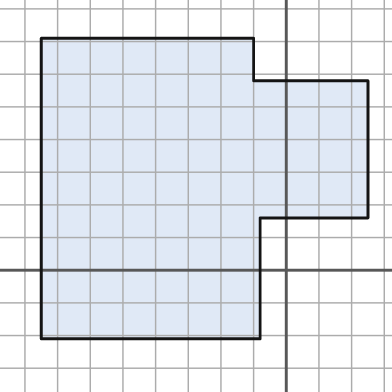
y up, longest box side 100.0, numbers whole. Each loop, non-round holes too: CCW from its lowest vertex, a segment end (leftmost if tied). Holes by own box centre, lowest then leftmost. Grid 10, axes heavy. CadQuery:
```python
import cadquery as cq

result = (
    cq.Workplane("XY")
    .moveTo(-75.0, -21.0)
    .lineTo(-8.0, -21.0)
    .lineTo(-8.0, 16.0)
    .lineTo(25.0, 16.0)
    .lineTo(25.0, 58.0)
    .lineTo(-10.0, 58.0)
    .lineTo(-10.0, 71.0)
    .lineTo(-75.0, 71.0)
    .close()
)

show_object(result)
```